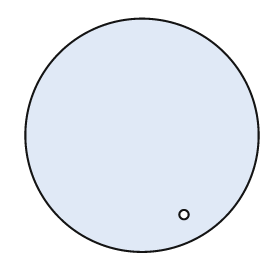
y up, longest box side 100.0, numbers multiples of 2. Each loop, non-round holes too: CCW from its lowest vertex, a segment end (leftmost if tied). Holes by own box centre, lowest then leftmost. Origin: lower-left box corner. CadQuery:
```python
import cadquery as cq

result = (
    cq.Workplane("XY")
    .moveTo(50.0, 50.0)
    .circle(50.0)
    .moveTo(68.0, 16.0)
    .circle(2.0)
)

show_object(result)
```